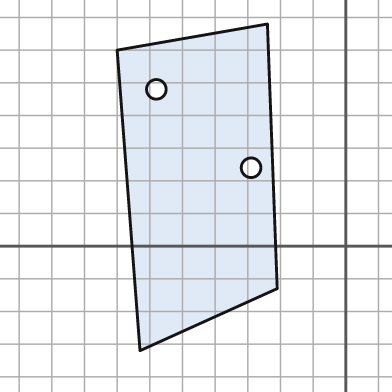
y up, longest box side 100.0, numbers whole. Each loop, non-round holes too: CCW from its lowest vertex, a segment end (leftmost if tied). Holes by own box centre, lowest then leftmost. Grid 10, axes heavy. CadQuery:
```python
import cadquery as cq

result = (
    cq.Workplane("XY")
    .moveTo(-63.0, -32.0)
    .lineTo(-21.0, -13.0)
    .lineTo(-24.0, 68.0)
    .lineTo(-70.0, 60.0)
    .close()
    .moveTo(-29.0, 24.0)
    .circle(3.0)
    .moveTo(-58.0, 48.0)
    .circle(3.0)
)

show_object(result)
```